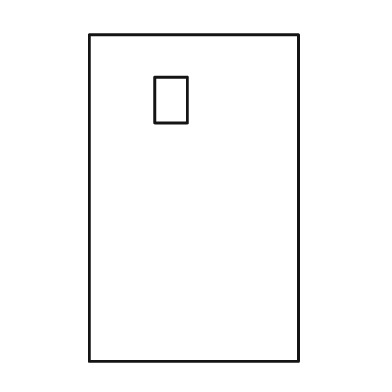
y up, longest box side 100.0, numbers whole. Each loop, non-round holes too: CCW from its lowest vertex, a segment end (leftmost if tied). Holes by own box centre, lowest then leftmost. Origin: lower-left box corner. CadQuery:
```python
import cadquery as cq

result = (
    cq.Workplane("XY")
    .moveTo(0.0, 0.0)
    .lineTo(64.0, 0.0)
    .lineTo(64.0, 100.0)
    .lineTo(0.0, 100.0)
    .close()
    .moveTo(20.0, 73.0)
    .lineTo(30.0, 73.0)
    .lineTo(30.0, 87.0)
    .lineTo(20.0, 87.0)
    .close()
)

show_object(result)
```